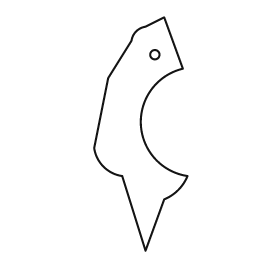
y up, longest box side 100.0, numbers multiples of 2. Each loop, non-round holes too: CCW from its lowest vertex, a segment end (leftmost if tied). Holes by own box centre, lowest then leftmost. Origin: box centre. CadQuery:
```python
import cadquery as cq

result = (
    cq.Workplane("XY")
    .moveTo(2.0, -50.0)
    .lineTo(10.0, -28.0)
    .threePointArc((16.0, -24.0), (20.0, -18.0))
    .threePointArc((0.0, 4.0), (18.0, 28.0))
    .lineTo(10.0, 50.0)
    .lineTo(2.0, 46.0)
    .threePointArc((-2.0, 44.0), (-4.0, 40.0))
    .lineTo(-14.0, 24.0)
    .lineTo(-20.0, -6.0)
    .threePointArc((-16.0, -14.0), (-8.0, -18.0))
    .close()
    .moveTo(6.0, 34.0)
    .circle(2.0)
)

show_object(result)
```